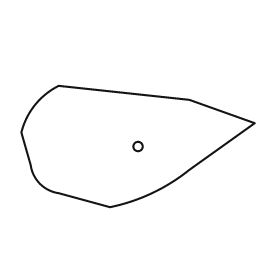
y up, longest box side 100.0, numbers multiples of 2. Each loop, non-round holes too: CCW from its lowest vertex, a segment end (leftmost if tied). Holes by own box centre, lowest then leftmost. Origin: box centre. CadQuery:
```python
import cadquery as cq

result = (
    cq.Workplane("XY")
    .moveTo(-12.0, -26.0)
    .threePointArc((6.0, -20.0), (22.0, -10.0))
    .lineTo(50.0, 10.0)
    .lineTo(22.0, 20.0)
    .lineTo(-34.0, 26.0)
    .threePointArc((-44.0, 18.0), (-50.0, 6.0))
    .lineTo(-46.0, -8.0)
    .threePointArc((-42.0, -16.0), (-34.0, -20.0))
    .close()
    .moveTo(0.0, 0.0)
    .circle(2.0)
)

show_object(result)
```